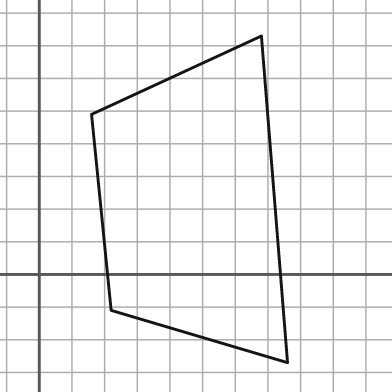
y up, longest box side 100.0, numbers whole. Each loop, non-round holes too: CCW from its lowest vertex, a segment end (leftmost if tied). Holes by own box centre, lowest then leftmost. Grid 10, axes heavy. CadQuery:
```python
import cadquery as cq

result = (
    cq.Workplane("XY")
    .moveTo(76.0, -27.0)
    .lineTo(68.0, 73.0)
    .lineTo(16.0, 49.0)
    .lineTo(22.0, -11.0)
    .close()
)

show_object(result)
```